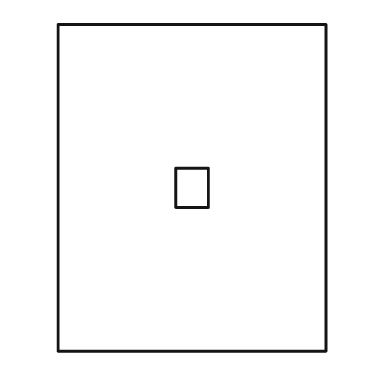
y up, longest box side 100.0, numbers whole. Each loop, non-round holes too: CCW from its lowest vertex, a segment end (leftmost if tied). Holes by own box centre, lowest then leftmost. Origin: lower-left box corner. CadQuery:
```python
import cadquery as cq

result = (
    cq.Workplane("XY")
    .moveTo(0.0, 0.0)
    .lineTo(82.0, 0.0)
    .lineTo(82.0, 100.0)
    .lineTo(0.0, 100.0)
    .close()
    .moveTo(36.0, 44.0)
    .lineTo(46.0, 44.0)
    .lineTo(46.0, 56.0)
    .lineTo(36.0, 56.0)
    .close()
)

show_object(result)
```